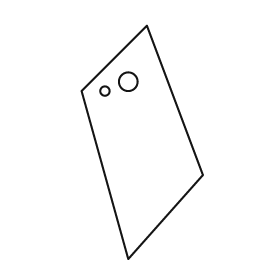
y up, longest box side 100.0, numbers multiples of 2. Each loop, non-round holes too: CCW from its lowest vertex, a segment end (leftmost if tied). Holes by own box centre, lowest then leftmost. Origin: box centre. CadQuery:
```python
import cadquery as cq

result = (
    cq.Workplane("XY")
    .moveTo(-6.0, -50.0)
    .lineTo(26.0, -14.0)
    .lineTo(2.0, 50.0)
    .lineTo(-26.0, 22.0)
    .close()
    .moveTo(-16.0, 22.0)
    .circle(2.0)
    .moveTo(-6.0, 26.0)
    .circle(4.0)
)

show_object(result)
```